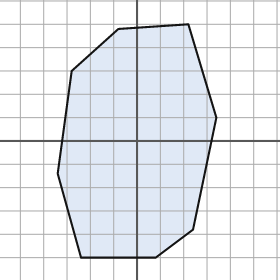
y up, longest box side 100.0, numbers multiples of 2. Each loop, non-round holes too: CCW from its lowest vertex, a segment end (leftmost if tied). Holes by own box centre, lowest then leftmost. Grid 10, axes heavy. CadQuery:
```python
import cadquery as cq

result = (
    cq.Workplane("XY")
    .moveTo(-24.0, -50.0)
    .lineTo(8.0, -50.0)
    .lineTo(24.0, -38.0)
    .lineTo(34.0, 10.0)
    .lineTo(22.0, 50.0)
    .lineTo(-8.0, 48.0)
    .lineTo(-28.0, 30.0)
    .lineTo(-34.0, -14.0)
    .close()
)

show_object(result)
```